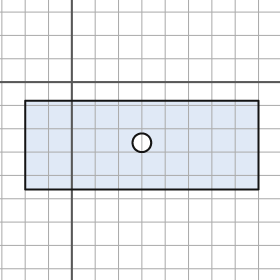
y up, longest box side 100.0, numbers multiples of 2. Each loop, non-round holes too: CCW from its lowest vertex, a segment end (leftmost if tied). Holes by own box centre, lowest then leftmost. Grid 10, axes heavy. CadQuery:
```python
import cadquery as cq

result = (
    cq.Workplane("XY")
    .moveTo(-20.0, -46.0)
    .lineTo(80.0, -46.0)
    .lineTo(80.0, -8.0)
    .lineTo(-20.0, -8.0)
    .close()
    .moveTo(30.0, -26.0)
    .circle(4.0)
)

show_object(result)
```